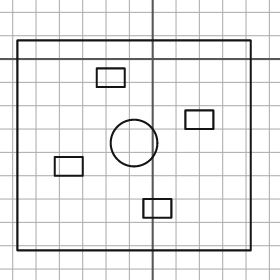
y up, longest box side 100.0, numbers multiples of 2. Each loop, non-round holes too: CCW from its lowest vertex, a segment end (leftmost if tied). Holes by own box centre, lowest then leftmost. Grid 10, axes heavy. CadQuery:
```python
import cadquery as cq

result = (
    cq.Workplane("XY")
    .moveTo(-58.0, -82.0)
    .lineTo(42.0, -82.0)
    .lineTo(42.0, 8.0)
    .lineTo(-58.0, 8.0)
    .close()
    .moveTo(-4.0, -68.0)
    .lineTo(8.0, -68.0)
    .lineTo(8.0, -60.0)
    .lineTo(-4.0, -60.0)
    .close()
    .moveTo(-42.0, -50.0)
    .lineTo(-30.0, -50.0)
    .lineTo(-30.0, -42.0)
    .lineTo(-42.0, -42.0)
    .close()
    .moveTo(-8.0, -36.0)
    .circle(10.0)
    .moveTo(14.0, -30.0)
    .lineTo(26.0, -30.0)
    .lineTo(26.0, -22.0)
    .lineTo(14.0, -22.0)
    .close()
    .moveTo(-24.0, -12.0)
    .lineTo(-12.0, -12.0)
    .lineTo(-12.0, -4.0)
    .lineTo(-24.0, -4.0)
    .close()
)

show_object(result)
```